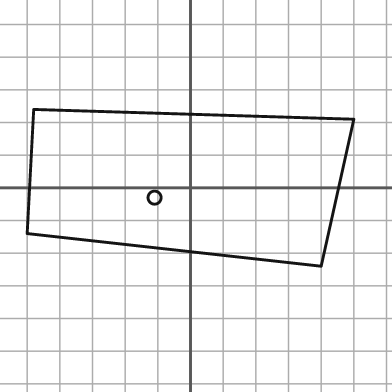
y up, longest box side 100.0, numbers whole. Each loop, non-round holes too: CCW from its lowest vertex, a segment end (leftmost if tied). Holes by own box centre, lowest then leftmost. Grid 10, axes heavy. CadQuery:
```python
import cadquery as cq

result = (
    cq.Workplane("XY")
    .moveTo(40.0, -24.0)
    .lineTo(50.0, 21.0)
    .lineTo(-48.0, 24.0)
    .lineTo(-50.0, -14.0)
    .close()
    .moveTo(-11.0, -3.0)
    .circle(2.0)
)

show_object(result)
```